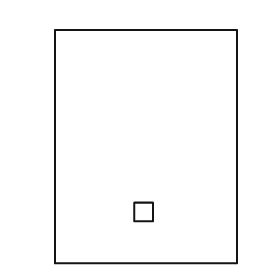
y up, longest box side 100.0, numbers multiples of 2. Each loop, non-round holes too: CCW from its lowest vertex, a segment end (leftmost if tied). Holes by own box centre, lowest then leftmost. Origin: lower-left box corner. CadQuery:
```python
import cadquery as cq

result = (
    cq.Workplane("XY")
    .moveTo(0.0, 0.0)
    .lineTo(78.0, 0.0)
    .lineTo(78.0, 100.0)
    .lineTo(0.0, 100.0)
    .close()
    .moveTo(34.0, 18.0)
    .lineTo(42.0, 18.0)
    .lineTo(42.0, 26.0)
    .lineTo(34.0, 26.0)
    .close()
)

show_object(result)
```